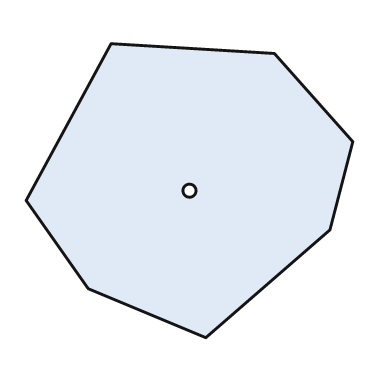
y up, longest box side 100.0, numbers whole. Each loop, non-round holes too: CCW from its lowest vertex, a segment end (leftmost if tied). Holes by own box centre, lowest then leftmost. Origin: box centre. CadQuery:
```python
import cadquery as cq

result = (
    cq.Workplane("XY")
    .moveTo(5.0, -45.0)
    .lineTo(43.0, -12.0)
    .lineTo(50.0, 15.0)
    .lineTo(26.0, 42.0)
    .lineTo(-24.0, 45.0)
    .lineTo(-50.0, -3.0)
    .lineTo(-31.0, -30.0)
    .close()
    .moveTo(0.0, 0.0)
    .circle(2.0)
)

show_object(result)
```